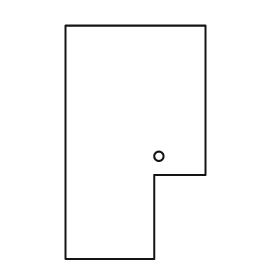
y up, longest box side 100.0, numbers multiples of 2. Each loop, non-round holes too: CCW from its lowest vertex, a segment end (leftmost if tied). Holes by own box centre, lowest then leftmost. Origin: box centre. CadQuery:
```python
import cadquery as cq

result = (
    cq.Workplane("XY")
    .moveTo(-30.0, -50.0)
    .lineTo(8.0, -50.0)
    .lineTo(8.0, -14.0)
    .lineTo(30.0, -14.0)
    .lineTo(30.0, 50.0)
    .lineTo(-30.0, 50.0)
    .close()
    .moveTo(10.0, -6.0)
    .circle(2.0)
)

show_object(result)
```